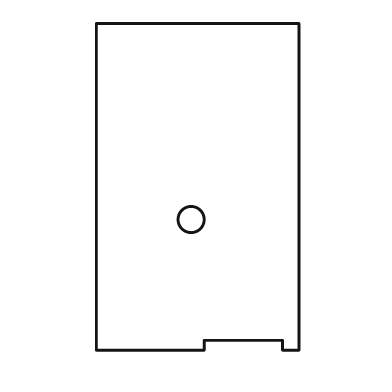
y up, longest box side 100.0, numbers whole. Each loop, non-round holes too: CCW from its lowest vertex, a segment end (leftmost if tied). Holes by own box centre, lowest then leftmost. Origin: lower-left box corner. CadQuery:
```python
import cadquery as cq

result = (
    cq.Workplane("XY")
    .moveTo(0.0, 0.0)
    .lineTo(33.0, 0.0)
    .lineTo(33.0, 3.0)
    .lineTo(57.0, 3.0)
    .lineTo(57.0, 0.0)
    .lineTo(62.0, 0.0)
    .lineTo(62.0, 100.0)
    .lineTo(0.0, 100.0)
    .close()
    .moveTo(29.0, 40.0)
    .circle(4.0)
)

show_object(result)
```